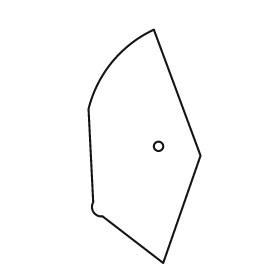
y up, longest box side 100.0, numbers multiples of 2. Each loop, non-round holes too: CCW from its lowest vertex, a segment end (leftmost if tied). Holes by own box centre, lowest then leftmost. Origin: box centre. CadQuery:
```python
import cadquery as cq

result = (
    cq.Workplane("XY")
    .moveTo(8.0, -50.0)
    .lineTo(24.0, -4.0)
    .lineTo(4.0, 50.0)
    .threePointArc((-14.0, 36.0), (-24.0, 16.0))
    .lineTo(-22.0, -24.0)
    .threePointArc((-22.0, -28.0), (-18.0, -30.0))
    .close()
    .moveTo(6.0, 0.0)
    .circle(2.0)
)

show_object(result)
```